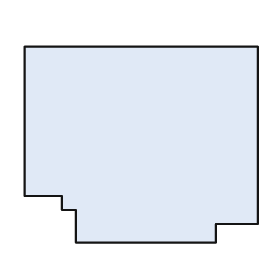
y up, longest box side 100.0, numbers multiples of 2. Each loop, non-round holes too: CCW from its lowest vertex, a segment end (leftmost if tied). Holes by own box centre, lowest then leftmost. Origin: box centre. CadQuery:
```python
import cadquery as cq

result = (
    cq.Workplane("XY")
    .moveTo(-28.0, -42.0)
    .lineTo(32.0, -42.0)
    .lineTo(32.0, -34.0)
    .lineTo(50.0, -34.0)
    .lineTo(50.0, 42.0)
    .lineTo(-50.0, 42.0)
    .lineTo(-50.0, -22.0)
    .lineTo(-34.0, -22.0)
    .lineTo(-34.0, -28.0)
    .lineTo(-28.0, -28.0)
    .close()
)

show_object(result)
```